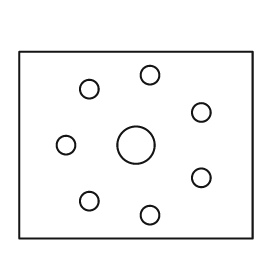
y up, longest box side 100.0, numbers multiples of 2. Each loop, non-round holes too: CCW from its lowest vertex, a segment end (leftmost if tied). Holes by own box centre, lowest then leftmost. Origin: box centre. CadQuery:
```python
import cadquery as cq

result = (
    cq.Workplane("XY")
    .moveTo(-50.0, -40.0)
    .lineTo(50.0, -40.0)
    .lineTo(50.0, 40.0)
    .lineTo(-50.0, 40.0)
    .close()
    .moveTo(6.0, -30.0)
    .circle(4.0)
    .moveTo(-20.0, -24.0)
    .circle(4.0)
    .moveTo(28.0, -14.0)
    .circle(4.0)
    .moveTo(-30.0, 0.0)
    .circle(4.0)
    .moveTo(0.0, 0.0)
    .circle(8.0)
    .moveTo(28.0, 14.0)
    .circle(4.0)
    .moveTo(-20.0, 24.0)
    .circle(4.0)
    .moveTo(6.0, 30.0)
    .circle(4.0)
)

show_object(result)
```